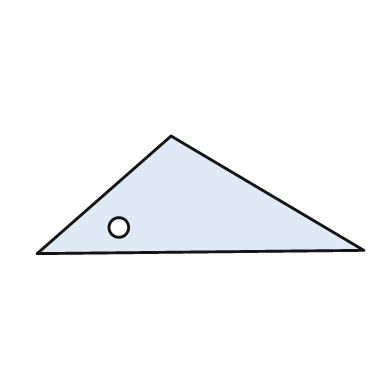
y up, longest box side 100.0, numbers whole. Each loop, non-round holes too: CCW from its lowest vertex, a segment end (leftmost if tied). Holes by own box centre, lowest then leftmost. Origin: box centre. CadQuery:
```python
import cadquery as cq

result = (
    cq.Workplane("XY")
    .moveTo(-50.0, -18.0)
    .lineTo(50.0, -17.0)
    .lineTo(-9.0, 18.0)
    .close()
    .moveTo(-25.0, -10.0)
    .circle(3.0)
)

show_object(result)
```